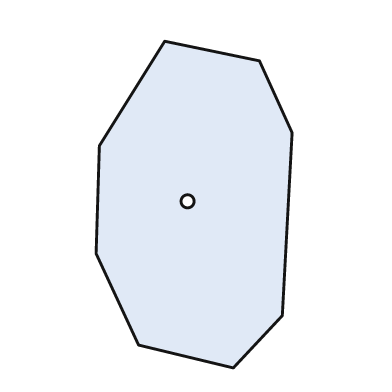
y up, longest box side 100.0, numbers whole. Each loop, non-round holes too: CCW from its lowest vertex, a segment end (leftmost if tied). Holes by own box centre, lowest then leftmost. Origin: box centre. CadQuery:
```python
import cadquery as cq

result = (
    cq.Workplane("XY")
    .moveTo(12.0, -50.0)
    .lineTo(27.0, -34.0)
    .lineTo(30.0, 22.0)
    .lineTo(20.0, 44.0)
    .lineTo(-9.0, 50.0)
    .lineTo(-29.0, 18.0)
    .lineTo(-30.0, -15.0)
    .lineTo(-17.0, -43.0)
    .close()
    .moveTo(-2.0, 1.0)
    .circle(2.0)
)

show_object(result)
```